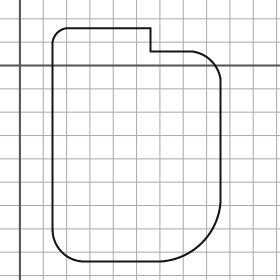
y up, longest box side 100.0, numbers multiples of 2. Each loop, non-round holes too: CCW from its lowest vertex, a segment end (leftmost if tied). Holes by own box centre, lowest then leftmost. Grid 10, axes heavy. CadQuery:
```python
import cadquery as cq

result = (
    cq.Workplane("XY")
    .moveTo(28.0, -84.0)
    .lineTo(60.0, -84.0)
    .threePointArc((78.0, -76.0), (86.0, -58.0))
    .lineTo(86.0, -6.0)
    .threePointArc((82.0, 2.0), (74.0, 6.0))
    .lineTo(56.0, 6.0)
    .lineTo(56.0, 16.0)
    .lineTo(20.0, 16.0)
    .threePointArc((16.0, 14.0), (14.0, 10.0))
    .lineTo(14.0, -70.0)
    .threePointArc((18.0, -80.0), (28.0, -84.0))
    .close()
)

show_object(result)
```